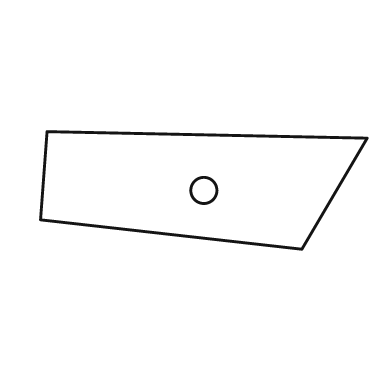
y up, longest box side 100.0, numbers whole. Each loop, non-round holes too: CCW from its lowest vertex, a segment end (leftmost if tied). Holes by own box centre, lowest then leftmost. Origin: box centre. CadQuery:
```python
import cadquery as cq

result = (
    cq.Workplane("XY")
    .moveTo(30.0, -18.0)
    .lineTo(50.0, 16.0)
    .lineTo(-48.0, 18.0)
    .lineTo(-50.0, -9.0)
    .close()
    .moveTo(0.0, 0.0)
    .circle(4.0)
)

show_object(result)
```